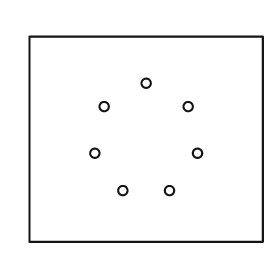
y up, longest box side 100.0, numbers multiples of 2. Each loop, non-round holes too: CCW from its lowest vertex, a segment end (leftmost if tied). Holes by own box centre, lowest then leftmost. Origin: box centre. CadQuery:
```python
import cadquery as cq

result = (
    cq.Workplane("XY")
    .moveTo(-50.0, -44.0)
    .lineTo(50.0, -44.0)
    .lineTo(50.0, 44.0)
    .lineTo(-50.0, 44.0)
    .close()
    .moveTo(-10.0, -22.0)
    .circle(2.0)
    .moveTo(10.0, -22.0)
    .circle(2.0)
    .moveTo(-22.0, -6.0)
    .circle(2.0)
    .moveTo(22.0, -6.0)
    .circle(2.0)
    .moveTo(-18.0, 14.0)
    .circle(2.0)
    .moveTo(18.0, 14.0)
    .circle(2.0)
    .moveTo(0.0, 24.0)
    .circle(2.0)
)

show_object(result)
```